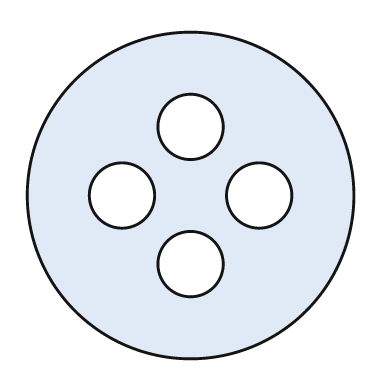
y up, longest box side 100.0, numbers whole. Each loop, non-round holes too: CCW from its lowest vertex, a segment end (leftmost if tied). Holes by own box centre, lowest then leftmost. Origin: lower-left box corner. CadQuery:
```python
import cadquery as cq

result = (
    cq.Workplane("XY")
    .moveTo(50.0, 50.0)
    .circle(50.0)
    .moveTo(50.0, 29.0)
    .circle(10.0)
    .moveTo(29.0, 50.0)
    .circle(10.0)
    .moveTo(71.0, 50.0)
    .circle(10.0)
    .moveTo(50.0, 71.0)
    .circle(10.0)
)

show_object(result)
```